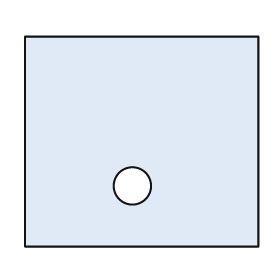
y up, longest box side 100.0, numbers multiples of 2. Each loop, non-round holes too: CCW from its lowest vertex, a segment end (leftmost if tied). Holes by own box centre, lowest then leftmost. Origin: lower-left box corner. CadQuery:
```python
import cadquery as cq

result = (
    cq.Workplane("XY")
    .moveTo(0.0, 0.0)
    .lineTo(100.0, 0.0)
    .lineTo(100.0, 90.0)
    .lineTo(0.0, 90.0)
    .close()
    .moveTo(46.0, 26.0)
    .circle(8.0)
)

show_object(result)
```